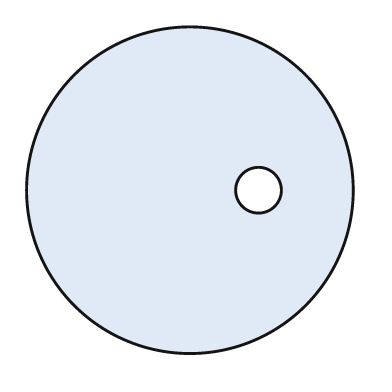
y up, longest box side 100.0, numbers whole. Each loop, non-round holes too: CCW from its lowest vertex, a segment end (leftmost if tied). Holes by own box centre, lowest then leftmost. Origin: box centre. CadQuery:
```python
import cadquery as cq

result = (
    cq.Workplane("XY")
    .moveTo(0.0, 0.0)
    .circle(50.0)
    .moveTo(21.0, 0.0)
    .circle(7.0)
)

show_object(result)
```